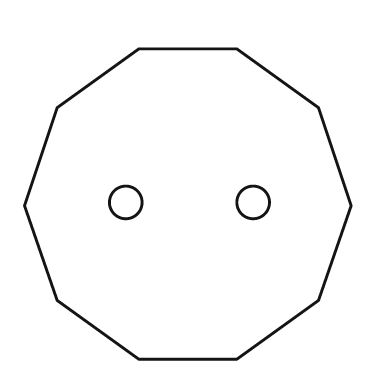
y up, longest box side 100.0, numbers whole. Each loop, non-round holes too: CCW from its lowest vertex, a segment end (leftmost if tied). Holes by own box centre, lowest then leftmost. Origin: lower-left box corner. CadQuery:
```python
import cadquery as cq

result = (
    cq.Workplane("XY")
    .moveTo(35.0, 0.0)
    .lineTo(65.0, 0.0)
    .lineTo(90.0, 18.0)
    .lineTo(100.0, 47.0)
    .lineTo(90.0, 77.0)
    .lineTo(65.0, 95.0)
    .lineTo(35.0, 95.0)
    .lineTo(10.0, 77.0)
    .lineTo(0.0, 47.0)
    .lineTo(10.0, 18.0)
    .close()
    .moveTo(31.0, 48.0)
    .circle(5.0)
    .moveTo(70.0, 48.0)
    .circle(5.0)
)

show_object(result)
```